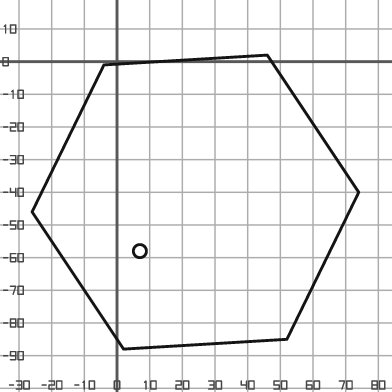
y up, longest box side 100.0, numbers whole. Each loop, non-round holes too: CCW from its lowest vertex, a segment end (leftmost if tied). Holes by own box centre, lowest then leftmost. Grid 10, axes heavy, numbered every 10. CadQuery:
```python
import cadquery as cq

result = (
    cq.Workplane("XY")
    .moveTo(2.0, -88.0)
    .lineTo(52.0, -85.0)
    .lineTo(74.0, -40.0)
    .lineTo(46.0, 2.0)
    .lineTo(-4.0, -1.0)
    .lineTo(-26.0, -46.0)
    .close()
    .moveTo(7.0, -58.0)
    .circle(2.0)
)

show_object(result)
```